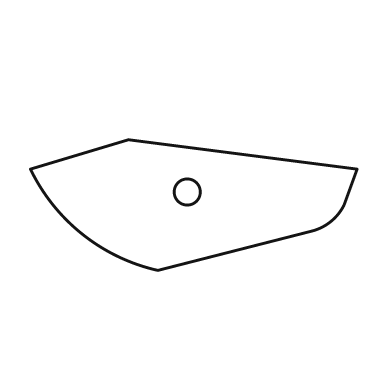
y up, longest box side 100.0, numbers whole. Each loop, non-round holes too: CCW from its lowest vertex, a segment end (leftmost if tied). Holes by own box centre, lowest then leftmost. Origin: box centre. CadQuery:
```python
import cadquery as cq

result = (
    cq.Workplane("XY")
    .moveTo(-11.0, -20.0)
    .lineTo(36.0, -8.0)
    .threePointArc((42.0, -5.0), (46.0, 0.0))
    .lineTo(50.0, 11.0)
    .lineTo(-20.0, 20.0)
    .lineTo(-50.0, 11.0)
    .threePointArc((-34.0, -9.0), (-11.0, -20.0))
    .close()
    .moveTo(-2.0, 4.0)
    .circle(4.0)
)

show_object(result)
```